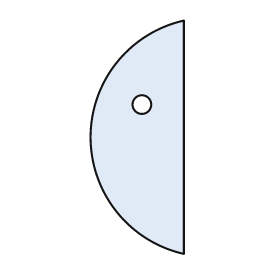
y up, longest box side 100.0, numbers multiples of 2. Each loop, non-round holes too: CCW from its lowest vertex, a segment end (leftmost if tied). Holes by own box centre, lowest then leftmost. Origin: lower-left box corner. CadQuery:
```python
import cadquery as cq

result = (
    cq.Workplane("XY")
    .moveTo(40.0, 0.0)
    .lineTo(40.0, 100.0)
    .threePointArc((0.0, 50.0), (40.0, 0.0))
    .close()
    .moveTo(22.0, 64.0)
    .circle(4.0)
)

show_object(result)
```